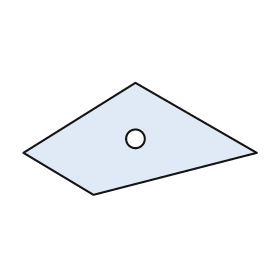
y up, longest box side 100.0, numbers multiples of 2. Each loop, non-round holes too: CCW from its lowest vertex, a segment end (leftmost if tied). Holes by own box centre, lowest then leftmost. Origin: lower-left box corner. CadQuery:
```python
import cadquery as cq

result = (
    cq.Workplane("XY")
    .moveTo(30.0, 0.0)
    .lineTo(100.0, 18.0)
    .lineTo(48.0, 48.0)
    .lineTo(0.0, 18.0)
    .close()
    .moveTo(48.0, 24.0)
    .circle(4.0)
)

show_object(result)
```